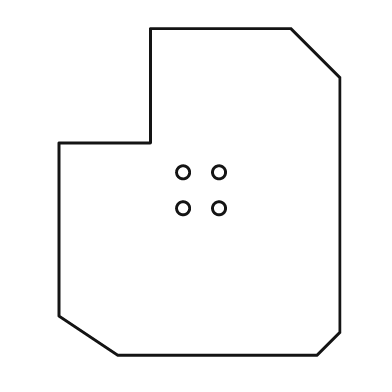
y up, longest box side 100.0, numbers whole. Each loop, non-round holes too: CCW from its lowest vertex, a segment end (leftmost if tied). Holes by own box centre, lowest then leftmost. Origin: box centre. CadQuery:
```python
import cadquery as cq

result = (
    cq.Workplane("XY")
    .moveTo(-25.0, -50.0)
    .lineTo(36.0, -50.0)
    .lineTo(43.0, -43.0)
    .lineTo(43.0, 35.0)
    .lineTo(28.0, 50.0)
    .lineTo(-15.0, 50.0)
    .lineTo(-15.0, 15.0)
    .lineTo(-43.0, 15.0)
    .lineTo(-43.0, -38.0)
    .close()
    .moveTo(-5.0, -5.0)
    .circle(2.0)
    .moveTo(6.0, -5.0)
    .circle(2.0)
    .moveTo(-5.0, 6.0)
    .circle(2.0)
    .moveTo(6.0, 6.0)
    .circle(2.0)
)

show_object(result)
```